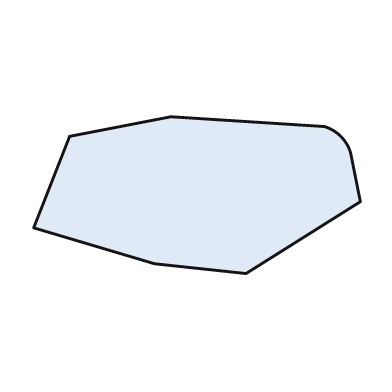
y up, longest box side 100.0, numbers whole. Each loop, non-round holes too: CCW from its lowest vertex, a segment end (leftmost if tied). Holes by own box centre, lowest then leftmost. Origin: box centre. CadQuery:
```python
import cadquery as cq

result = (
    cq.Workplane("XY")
    .moveTo(15.0, -24.0)
    .lineTo(50.0, -2.0)
    .lineTo(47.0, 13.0)
    .threePointArc((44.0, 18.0), (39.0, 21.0))
    .lineTo(-8.0, 24.0)
    .lineTo(-39.0, 18.0)
    .lineTo(-50.0, -10.0)
    .lineTo(-13.0, -21.0)
    .close()
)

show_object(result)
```